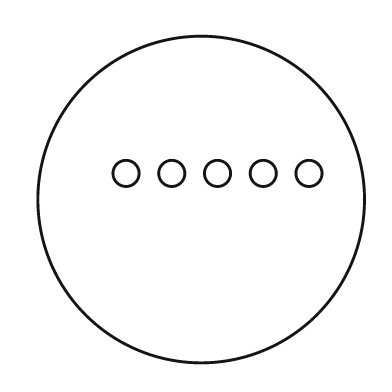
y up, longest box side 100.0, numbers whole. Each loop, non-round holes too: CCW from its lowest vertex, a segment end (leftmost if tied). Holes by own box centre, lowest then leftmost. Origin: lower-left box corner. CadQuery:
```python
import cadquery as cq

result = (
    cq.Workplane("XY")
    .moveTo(50.0, 50.0)
    .circle(50.0)
    .moveTo(27.0, 58.0)
    .circle(4.0)
    .moveTo(41.0, 58.0)
    .circle(4.0)
    .moveTo(55.0, 58.0)
    .circle(4.0)
    .moveTo(69.0, 58.0)
    .circle(4.0)
    .moveTo(83.0, 58.0)
    .circle(4.0)
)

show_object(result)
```